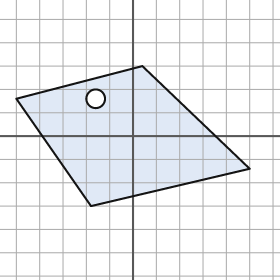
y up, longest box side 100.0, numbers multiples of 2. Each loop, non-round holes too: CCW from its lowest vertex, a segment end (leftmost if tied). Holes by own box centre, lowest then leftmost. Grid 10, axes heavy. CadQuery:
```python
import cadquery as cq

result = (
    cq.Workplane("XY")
    .moveTo(-18.0, -30.0)
    .lineTo(50.0, -14.0)
    .lineTo(4.0, 30.0)
    .lineTo(-50.0, 16.0)
    .close()
    .moveTo(-16.0, 16.0)
    .circle(4.0)
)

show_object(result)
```